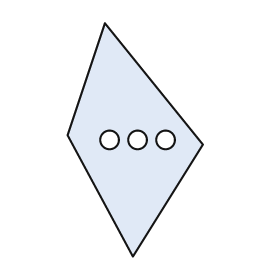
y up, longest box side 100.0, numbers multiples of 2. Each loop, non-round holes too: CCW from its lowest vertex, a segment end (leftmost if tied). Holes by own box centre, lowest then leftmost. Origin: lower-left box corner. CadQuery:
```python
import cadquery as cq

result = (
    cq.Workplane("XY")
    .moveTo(28.0, 0.0)
    .lineTo(58.0, 48.0)
    .lineTo(16.0, 100.0)
    .lineTo(0.0, 52.0)
    .close()
    .moveTo(18.0, 50.0)
    .circle(4.0)
    .moveTo(30.0, 50.0)
    .circle(4.0)
    .moveTo(42.0, 50.0)
    .circle(4.0)
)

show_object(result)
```